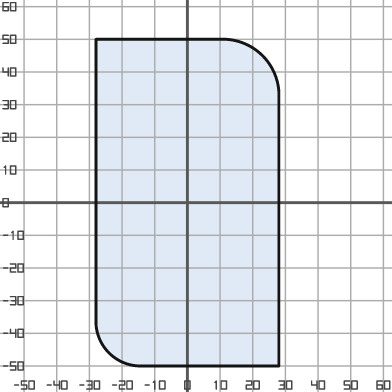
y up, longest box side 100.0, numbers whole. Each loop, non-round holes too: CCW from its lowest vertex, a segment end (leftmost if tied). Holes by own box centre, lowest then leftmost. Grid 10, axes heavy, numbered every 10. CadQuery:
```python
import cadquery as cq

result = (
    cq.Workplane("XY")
    .moveTo(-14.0, -50.0)
    .lineTo(28.0, -50.0)
    .lineTo(28.0, 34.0)
    .threePointArc((23.0, 45.0), (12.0, 50.0))
    .lineTo(-28.0, 50.0)
    .lineTo(-28.0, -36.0)
    .threePointArc((-24.0, -46.0), (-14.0, -50.0))
    .close()
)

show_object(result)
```